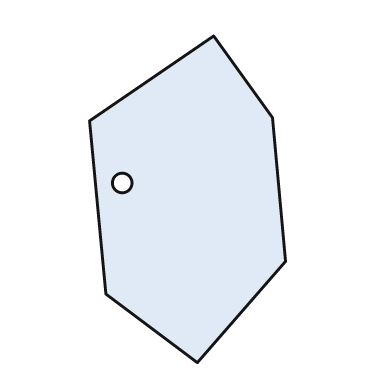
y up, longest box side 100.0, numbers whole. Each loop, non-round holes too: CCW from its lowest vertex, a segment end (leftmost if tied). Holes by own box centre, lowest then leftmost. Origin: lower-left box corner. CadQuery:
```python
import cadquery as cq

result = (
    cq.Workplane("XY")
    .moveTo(33.0, 0.0)
    .lineTo(60.0, 31.0)
    .lineTo(56.0, 75.0)
    .lineTo(38.0, 100.0)
    .lineTo(0.0, 74.0)
    .lineTo(5.0, 21.0)
    .close()
    .moveTo(10.0, 55.0)
    .circle(3.0)
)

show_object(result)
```